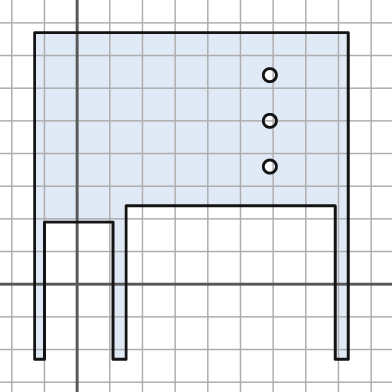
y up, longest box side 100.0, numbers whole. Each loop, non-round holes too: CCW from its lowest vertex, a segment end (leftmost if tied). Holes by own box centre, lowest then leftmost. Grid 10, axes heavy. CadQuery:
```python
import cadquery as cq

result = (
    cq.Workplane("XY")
    .moveTo(-13.0, -23.0)
    .lineTo(-10.0, -23.0)
    .lineTo(-10.0, 19.0)
    .lineTo(11.0, 19.0)
    .lineTo(11.0, -23.0)
    .lineTo(15.0, -23.0)
    .lineTo(15.0, 24.0)
    .lineTo(79.0, 24.0)
    .lineTo(79.0, -23.0)
    .lineTo(83.0, -23.0)
    .lineTo(83.0, 77.0)
    .lineTo(-13.0, 77.0)
    .close()
    .moveTo(59.0, 36.0)
    .circle(2.0)
    .moveTo(59.0, 50.0)
    .circle(2.0)
    .moveTo(59.0, 64.0)
    .circle(2.0)
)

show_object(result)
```